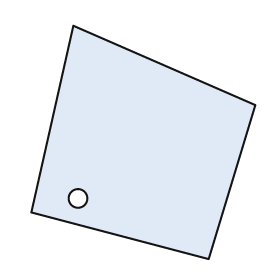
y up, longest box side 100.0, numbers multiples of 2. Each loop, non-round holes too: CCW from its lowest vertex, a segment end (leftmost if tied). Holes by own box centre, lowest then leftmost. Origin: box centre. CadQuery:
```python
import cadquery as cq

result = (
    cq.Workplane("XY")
    .moveTo(28.0, -50.0)
    .lineTo(48.0, 16.0)
    .lineTo(-30.0, 50.0)
    .lineTo(-48.0, -30.0)
    .close()
    .moveTo(-28.0, -24.0)
    .circle(4.0)
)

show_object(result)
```